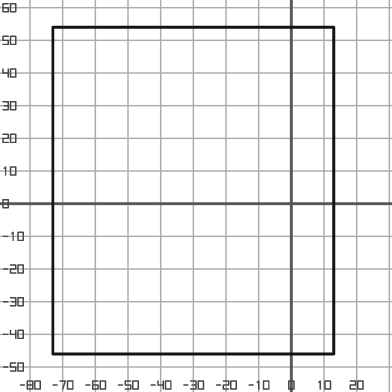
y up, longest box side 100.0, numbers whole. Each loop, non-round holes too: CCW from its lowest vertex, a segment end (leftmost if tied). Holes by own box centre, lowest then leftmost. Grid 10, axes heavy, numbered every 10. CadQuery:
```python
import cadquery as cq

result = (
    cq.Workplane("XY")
    .moveTo(-73.0, -46.0)
    .lineTo(13.0, -46.0)
    .lineTo(13.0, 54.0)
    .lineTo(-73.0, 54.0)
    .close()
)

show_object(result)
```